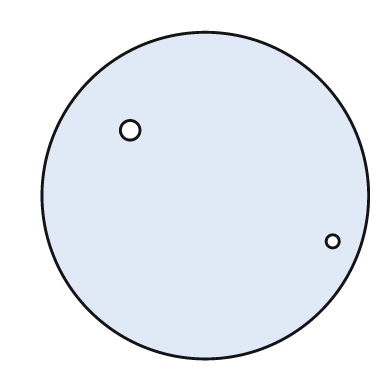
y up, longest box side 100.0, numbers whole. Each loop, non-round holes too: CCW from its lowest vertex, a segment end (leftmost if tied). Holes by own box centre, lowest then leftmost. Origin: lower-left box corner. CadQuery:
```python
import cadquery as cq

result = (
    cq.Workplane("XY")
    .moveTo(50.0, 50.0)
    .circle(50.0)
    .moveTo(89.0, 36.0)
    .circle(2.0)
    .moveTo(27.0, 70.0)
    .circle(3.0)
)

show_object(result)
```